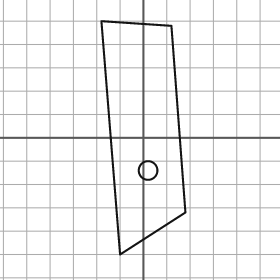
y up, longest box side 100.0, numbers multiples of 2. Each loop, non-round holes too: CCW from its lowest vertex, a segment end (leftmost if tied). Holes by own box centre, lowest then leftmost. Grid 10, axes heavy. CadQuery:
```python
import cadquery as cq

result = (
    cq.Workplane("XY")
    .moveTo(-10.0, -50.0)
    .lineTo(18.0, -32.0)
    .lineTo(12.0, 48.0)
    .lineTo(-18.0, 50.0)
    .close()
    .moveTo(2.0, -14.0)
    .circle(4.0)
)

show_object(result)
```